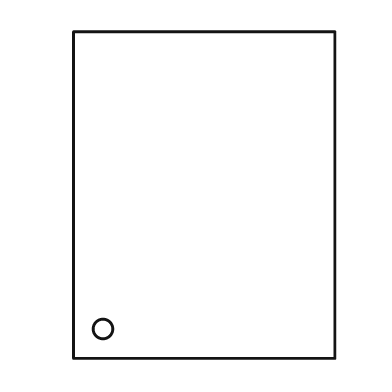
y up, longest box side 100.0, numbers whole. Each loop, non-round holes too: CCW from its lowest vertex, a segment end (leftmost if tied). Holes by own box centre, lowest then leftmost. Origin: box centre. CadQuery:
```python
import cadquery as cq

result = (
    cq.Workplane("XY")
    .moveTo(-40.0, -50.0)
    .lineTo(40.0, -50.0)
    .lineTo(40.0, 50.0)
    .lineTo(-40.0, 50.0)
    .close()
    .moveTo(-31.0, -41.0)
    .circle(3.0)
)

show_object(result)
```